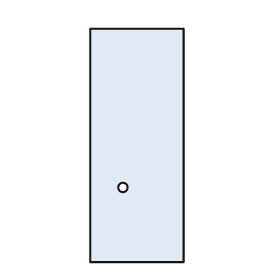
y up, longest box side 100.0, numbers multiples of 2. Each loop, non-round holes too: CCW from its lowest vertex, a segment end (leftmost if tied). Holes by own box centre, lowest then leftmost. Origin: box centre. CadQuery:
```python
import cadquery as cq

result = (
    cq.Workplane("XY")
    .moveTo(-20.0, -50.0)
    .lineTo(20.0, -50.0)
    .lineTo(20.0, 50.0)
    .lineTo(-20.0, 50.0)
    .close()
    .moveTo(-6.0, -18.0)
    .circle(2.0)
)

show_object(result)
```